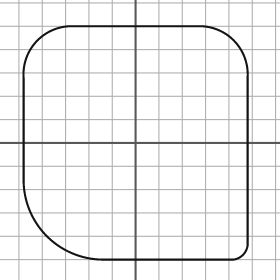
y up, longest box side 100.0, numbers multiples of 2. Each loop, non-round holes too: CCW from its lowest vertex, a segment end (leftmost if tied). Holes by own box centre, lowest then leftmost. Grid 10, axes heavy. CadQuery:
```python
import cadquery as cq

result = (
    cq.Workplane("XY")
    .moveTo(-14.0, -50.0)
    .lineTo(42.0, -50.0)
    .threePointArc((46.0, -48.0), (48.0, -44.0))
    .lineTo(48.0, 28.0)
    .threePointArc((42.0, 44.0), (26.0, 50.0))
    .lineTo(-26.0, 50.0)
    .threePointArc((-42.0, 44.0), (-48.0, 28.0))
    .lineTo(-48.0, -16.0)
    .threePointArc((-38.0, -40.0), (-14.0, -50.0))
    .close()
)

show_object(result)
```